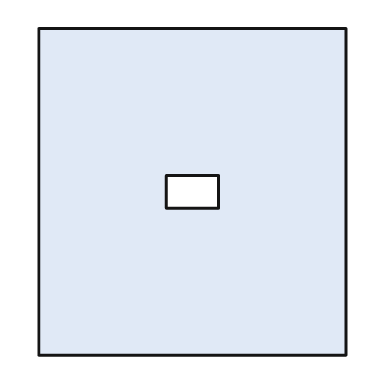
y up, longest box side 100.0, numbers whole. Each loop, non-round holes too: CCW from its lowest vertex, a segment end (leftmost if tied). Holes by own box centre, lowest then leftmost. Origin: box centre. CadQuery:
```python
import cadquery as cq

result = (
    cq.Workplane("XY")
    .moveTo(-47.0, -50.0)
    .lineTo(47.0, -50.0)
    .lineTo(47.0, 50.0)
    .lineTo(-47.0, 50.0)
    .close()
    .moveTo(-8.0, -5.0)
    .lineTo(8.0, -5.0)
    .lineTo(8.0, 5.0)
    .lineTo(-8.0, 5.0)
    .close()
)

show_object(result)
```